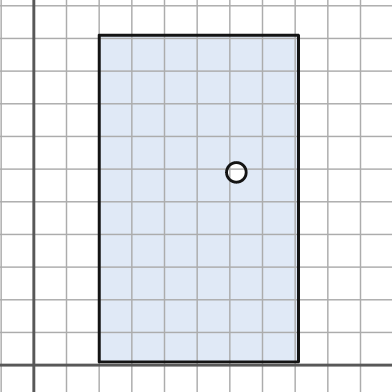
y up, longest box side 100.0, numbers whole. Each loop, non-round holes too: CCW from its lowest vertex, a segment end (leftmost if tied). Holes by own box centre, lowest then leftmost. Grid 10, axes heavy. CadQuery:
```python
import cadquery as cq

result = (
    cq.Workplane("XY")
    .moveTo(20.0, 1.0)
    .lineTo(81.0, 1.0)
    .lineTo(81.0, 101.0)
    .lineTo(20.0, 101.0)
    .close()
    .moveTo(62.0, 59.0)
    .circle(3.0)
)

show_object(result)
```